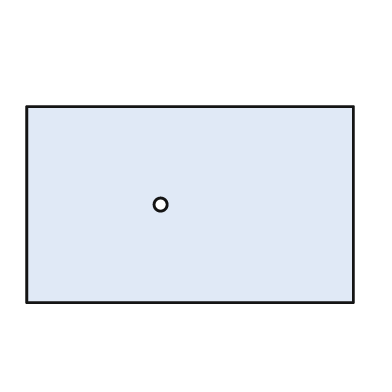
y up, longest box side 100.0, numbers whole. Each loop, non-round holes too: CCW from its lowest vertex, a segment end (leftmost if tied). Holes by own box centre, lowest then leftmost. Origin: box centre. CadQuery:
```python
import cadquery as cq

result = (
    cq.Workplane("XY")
    .moveTo(-50.0, -30.0)
    .lineTo(50.0, -30.0)
    .lineTo(50.0, 30.0)
    .lineTo(-50.0, 30.0)
    .close()
    .moveTo(-9.0, 0.0)
    .circle(2.0)
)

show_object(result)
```